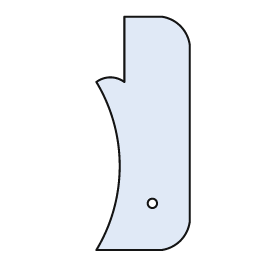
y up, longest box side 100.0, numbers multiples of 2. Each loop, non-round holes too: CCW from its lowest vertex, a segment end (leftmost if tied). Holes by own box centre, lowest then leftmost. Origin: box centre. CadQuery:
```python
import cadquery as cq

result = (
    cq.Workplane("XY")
    .moveTo(-20.0, -50.0)
    .lineTo(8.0, -50.0)
    .threePointArc((16.0, -46.0), (20.0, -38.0))
    .lineTo(20.0, 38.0)
    .threePointArc((16.0, 46.0), (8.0, 50.0))
    .lineTo(-8.0, 50.0)
    .lineTo(-8.0, 22.0)
    .threePointArc((-14.0, 24.0), (-20.0, 22.0))
    .threePointArc((-10.0, -14.0), (-20.0, -50.0))
    .close()
    .moveTo(4.0, -30.0)
    .circle(2.0)
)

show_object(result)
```